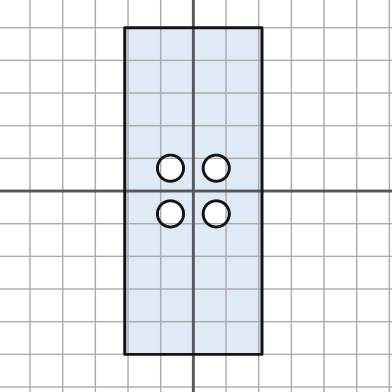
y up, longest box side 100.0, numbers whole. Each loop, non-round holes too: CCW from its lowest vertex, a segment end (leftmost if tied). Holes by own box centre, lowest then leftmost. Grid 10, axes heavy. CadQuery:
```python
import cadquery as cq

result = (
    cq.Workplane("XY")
    .moveTo(-21.0, -50.0)
    .lineTo(21.0, -50.0)
    .lineTo(21.0, 50.0)
    .lineTo(-21.0, 50.0)
    .close()
    .moveTo(-7.0, -7.0)
    .circle(4.0)
    .moveTo(7.0, -7.0)
    .circle(4.0)
    .moveTo(-7.0, 7.0)
    .circle(4.0)
    .moveTo(7.0, 7.0)
    .circle(4.0)
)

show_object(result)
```